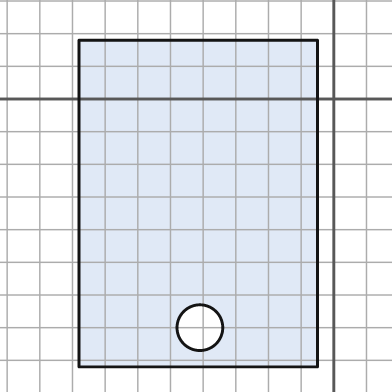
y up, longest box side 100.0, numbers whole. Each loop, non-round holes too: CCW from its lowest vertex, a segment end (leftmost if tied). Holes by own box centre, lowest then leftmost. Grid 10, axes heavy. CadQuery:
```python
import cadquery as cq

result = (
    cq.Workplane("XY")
    .moveTo(-78.0, -82.0)
    .lineTo(-5.0, -82.0)
    .lineTo(-5.0, 18.0)
    .lineTo(-78.0, 18.0)
    .close()
    .moveTo(-41.0, -70.0)
    .circle(7.0)
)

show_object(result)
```